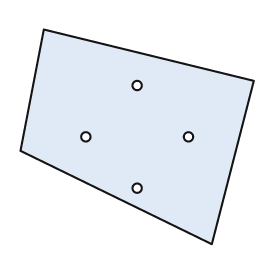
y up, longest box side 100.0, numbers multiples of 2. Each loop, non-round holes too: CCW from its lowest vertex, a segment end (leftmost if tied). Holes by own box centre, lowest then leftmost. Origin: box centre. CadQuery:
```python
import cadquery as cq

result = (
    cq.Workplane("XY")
    .moveTo(32.0, -46.0)
    .lineTo(50.0, 24.0)
    .lineTo(-40.0, 46.0)
    .lineTo(-50.0, -6.0)
    .close()
    .moveTo(0.0, -22.0)
    .circle(2.0)
    .moveTo(-22.0, 0.0)
    .circle(2.0)
    .moveTo(22.0, 0.0)
    .circle(2.0)
    .moveTo(0.0, 22.0)
    .circle(2.0)
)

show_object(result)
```